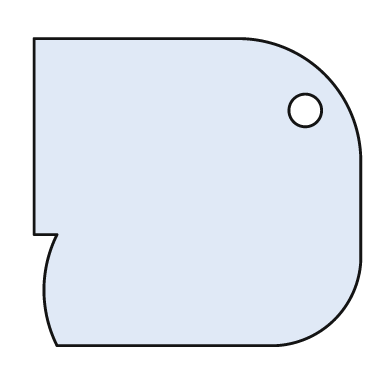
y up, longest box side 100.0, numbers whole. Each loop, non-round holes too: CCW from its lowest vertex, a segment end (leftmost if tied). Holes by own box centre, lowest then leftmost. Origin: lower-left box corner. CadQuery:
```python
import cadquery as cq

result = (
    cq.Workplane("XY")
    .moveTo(7.0, 0.0)
    .lineTo(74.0, 0.0)
    .threePointArc((92.0, 8.0), (100.0, 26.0))
    .lineTo(100.0, 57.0)
    .threePointArc((89.0, 83.0), (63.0, 94.0))
    .lineTo(0.0, 94.0)
    .lineTo(0.0, 34.0)
    .lineTo(7.0, 34.0)
    .threePointArc((3.0, 17.0), (7.0, 0.0))
    .close()
    .moveTo(83.0, 72.0)
    .circle(5.0)
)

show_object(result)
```